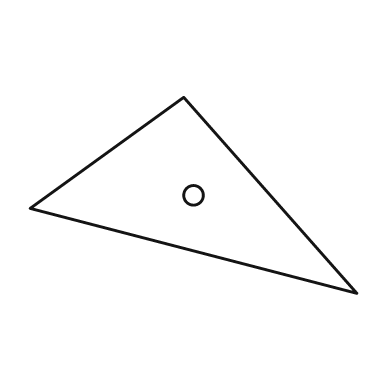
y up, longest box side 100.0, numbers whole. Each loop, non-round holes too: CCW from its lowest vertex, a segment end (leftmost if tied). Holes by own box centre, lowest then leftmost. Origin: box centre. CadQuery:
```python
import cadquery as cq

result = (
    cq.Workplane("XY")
    .moveTo(50.0, -30.0)
    .lineTo(-3.0, 30.0)
    .lineTo(-50.0, -4.0)
    .close()
    .moveTo(0.0, 0.0)
    .circle(3.0)
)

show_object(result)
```